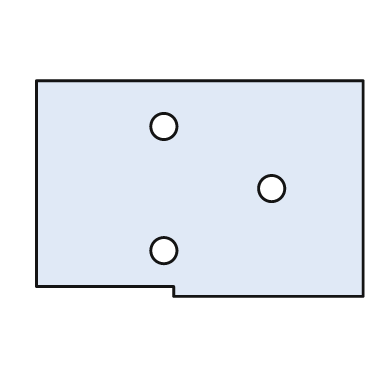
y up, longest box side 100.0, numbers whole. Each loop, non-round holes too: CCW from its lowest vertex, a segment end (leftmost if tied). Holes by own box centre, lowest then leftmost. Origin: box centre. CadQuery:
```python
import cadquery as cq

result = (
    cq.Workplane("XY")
    .moveTo(-8.0, -33.0)
    .lineTo(50.0, -33.0)
    .lineTo(50.0, 33.0)
    .lineTo(-50.0, 33.0)
    .lineTo(-50.0, -30.0)
    .lineTo(-8.0, -30.0)
    .close()
    .moveTo(-11.0, -19.0)
    .circle(4.0)
    .moveTo(22.0, 0.0)
    .circle(4.0)
    .moveTo(-11.0, 19.0)
    .circle(4.0)
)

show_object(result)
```